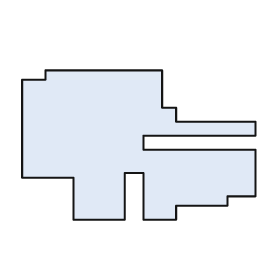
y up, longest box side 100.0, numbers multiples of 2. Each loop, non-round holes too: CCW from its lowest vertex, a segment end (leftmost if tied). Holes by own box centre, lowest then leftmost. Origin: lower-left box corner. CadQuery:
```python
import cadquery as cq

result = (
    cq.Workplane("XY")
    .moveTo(22.0, 0.0)
    .lineTo(44.0, 0.0)
    .lineTo(44.0, 20.0)
    .lineTo(52.0, 20.0)
    .lineTo(52.0, 0.0)
    .lineTo(66.0, 0.0)
    .lineTo(66.0, 6.0)
    .lineTo(88.0, 6.0)
    .lineTo(88.0, 10.0)
    .lineTo(100.0, 10.0)
    .lineTo(100.0, 30.0)
    .lineTo(52.0, 30.0)
    .lineTo(52.0, 36.0)
    .lineTo(100.0, 36.0)
    .lineTo(100.0, 42.0)
    .lineTo(66.0, 42.0)
    .lineTo(66.0, 48.0)
    .lineTo(60.0, 48.0)
    .lineTo(60.0, 64.0)
    .lineTo(10.0, 64.0)
    .lineTo(10.0, 60.0)
    .lineTo(0.0, 60.0)
    .lineTo(0.0, 18.0)
    .lineTo(22.0, 18.0)
    .close()
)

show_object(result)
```